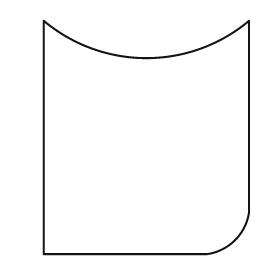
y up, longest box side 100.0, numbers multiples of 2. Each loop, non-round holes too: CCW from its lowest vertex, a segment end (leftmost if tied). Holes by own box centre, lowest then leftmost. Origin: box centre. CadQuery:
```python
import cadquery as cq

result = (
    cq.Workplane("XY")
    .moveTo(-44.0, -50.0)
    .lineTo(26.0, -50.0)
    .threePointArc((38.0, -44.0), (44.0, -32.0))
    .lineTo(44.0, 50.0)
    .threePointArc((0.0, 34.0), (-44.0, 50.0))
    .close()
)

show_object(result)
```